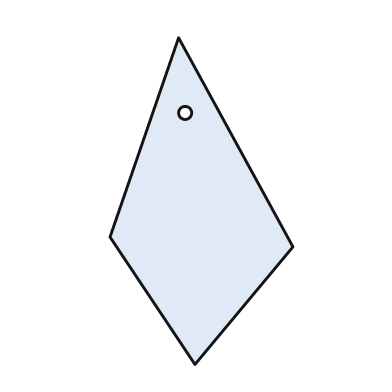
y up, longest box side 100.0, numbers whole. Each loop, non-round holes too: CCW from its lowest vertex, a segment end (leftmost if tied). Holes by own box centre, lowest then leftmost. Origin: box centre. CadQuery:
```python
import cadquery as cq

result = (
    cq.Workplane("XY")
    .moveTo(-2.0, -50.0)
    .lineTo(28.0, -14.0)
    .lineTo(-7.0, 50.0)
    .lineTo(-28.0, -11.0)
    .close()
    .moveTo(-5.0, 27.0)
    .circle(2.0)
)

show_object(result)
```